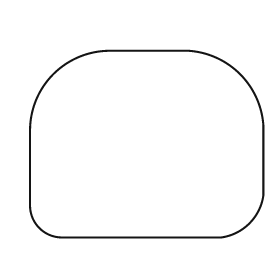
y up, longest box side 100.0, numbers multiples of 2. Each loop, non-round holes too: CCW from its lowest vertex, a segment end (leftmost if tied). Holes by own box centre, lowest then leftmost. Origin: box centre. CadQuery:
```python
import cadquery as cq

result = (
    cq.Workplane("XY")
    .moveTo(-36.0, -40.0)
    .lineTo(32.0, -40.0)
    .threePointArc((44.0, -34.0), (50.0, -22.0))
    .lineTo(50.0, 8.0)
    .threePointArc((40.0, 30.0), (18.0, 40.0))
    .lineTo(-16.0, 40.0)
    .threePointArc((-40.0, 30.0), (-50.0, 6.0))
    .lineTo(-50.0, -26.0)
    .threePointArc((-46.0, -36.0), (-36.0, -40.0))
    .close()
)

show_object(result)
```